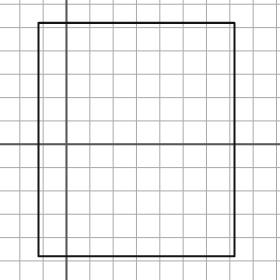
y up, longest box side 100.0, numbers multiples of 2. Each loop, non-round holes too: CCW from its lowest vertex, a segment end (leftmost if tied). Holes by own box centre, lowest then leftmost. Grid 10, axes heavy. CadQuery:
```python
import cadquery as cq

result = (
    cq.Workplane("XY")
    .moveTo(-12.0, -48.0)
    .lineTo(72.0, -48.0)
    .lineTo(72.0, 52.0)
    .lineTo(-12.0, 52.0)
    .close()
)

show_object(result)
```